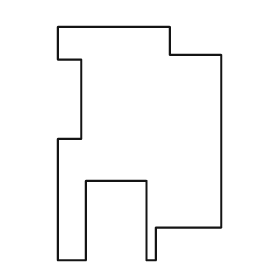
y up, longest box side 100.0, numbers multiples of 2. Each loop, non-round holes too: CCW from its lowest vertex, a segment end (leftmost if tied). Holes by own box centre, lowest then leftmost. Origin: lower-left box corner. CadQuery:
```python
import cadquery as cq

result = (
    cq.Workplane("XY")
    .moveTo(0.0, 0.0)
    .lineTo(12.0, 0.0)
    .lineTo(12.0, 34.0)
    .lineTo(38.0, 34.0)
    .lineTo(38.0, 0.0)
    .lineTo(42.0, 0.0)
    .lineTo(42.0, 14.0)
    .lineTo(70.0, 14.0)
    .lineTo(70.0, 88.0)
    .lineTo(48.0, 88.0)
    .lineTo(48.0, 100.0)
    .lineTo(0.0, 100.0)
    .lineTo(0.0, 86.0)
    .lineTo(10.0, 86.0)
    .lineTo(10.0, 52.0)
    .lineTo(0.0, 52.0)
    .close()
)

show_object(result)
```